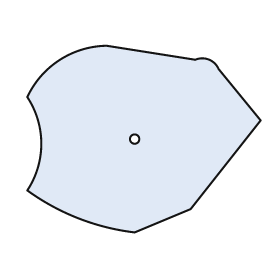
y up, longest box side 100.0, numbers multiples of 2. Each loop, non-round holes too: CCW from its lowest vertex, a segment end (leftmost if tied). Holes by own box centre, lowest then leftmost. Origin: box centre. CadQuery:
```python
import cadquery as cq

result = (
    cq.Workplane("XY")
    .moveTo(-4.0, -40.0)
    .lineTo(20.0, -30.0)
    .lineTo(50.0, 8.0)
    .lineTo(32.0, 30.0)
    .threePointArc((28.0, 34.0), (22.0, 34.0))
    .lineTo(-16.0, 40.0)
    .threePointArc((-36.0, 34.0), (-50.0, 18.0))
    .threePointArc((-44.0, -2.0), (-50.0, -22.0))
    .threePointArc((-28.0, -34.0), (-4.0, -40.0))
    .close()
    .moveTo(-4.0, 0.0)
    .circle(2.0)
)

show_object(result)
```